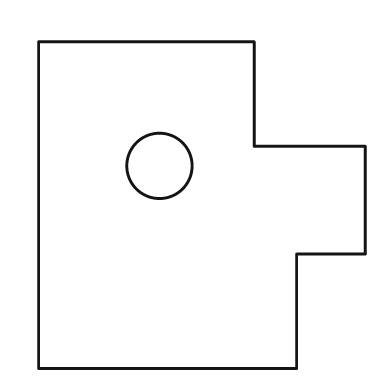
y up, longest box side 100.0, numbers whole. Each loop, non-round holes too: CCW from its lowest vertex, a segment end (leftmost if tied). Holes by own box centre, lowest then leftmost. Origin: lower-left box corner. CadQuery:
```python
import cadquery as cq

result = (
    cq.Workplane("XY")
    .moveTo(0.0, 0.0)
    .lineTo(79.0, 0.0)
    .lineTo(79.0, 35.0)
    .lineTo(100.0, 35.0)
    .lineTo(100.0, 68.0)
    .lineTo(66.0, 68.0)
    .lineTo(66.0, 100.0)
    .lineTo(0.0, 100.0)
    .close()
    .moveTo(37.0, 62.0)
    .circle(10.0)
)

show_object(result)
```